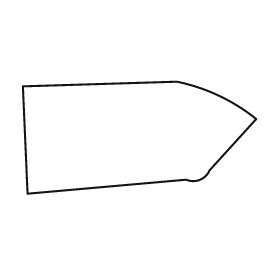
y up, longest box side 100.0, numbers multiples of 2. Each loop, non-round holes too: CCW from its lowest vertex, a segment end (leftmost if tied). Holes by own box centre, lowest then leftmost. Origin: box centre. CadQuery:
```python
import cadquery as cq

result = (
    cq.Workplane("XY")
    .moveTo(-48.0, -24.0)
    .lineTo(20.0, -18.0)
    .threePointArc((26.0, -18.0), (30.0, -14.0))
    .lineTo(50.0, 8.0)
    .threePointArc((34.0, 18.0), (16.0, 24.0))
    .lineTo(-50.0, 22.0)
    .close()
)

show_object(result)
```